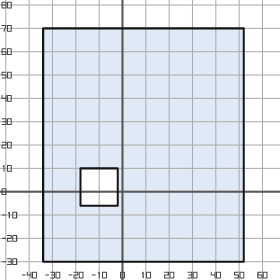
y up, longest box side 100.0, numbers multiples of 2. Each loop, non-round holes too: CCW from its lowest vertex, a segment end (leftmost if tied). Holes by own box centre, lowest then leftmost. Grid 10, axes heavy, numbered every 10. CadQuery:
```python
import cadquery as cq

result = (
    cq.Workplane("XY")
    .moveTo(-34.0, -30.0)
    .lineTo(52.0, -30.0)
    .lineTo(52.0, 70.0)
    .lineTo(-34.0, 70.0)
    .close()
    .moveTo(-18.0, -6.0)
    .lineTo(-2.0, -6.0)
    .lineTo(-2.0, 10.0)
    .lineTo(-18.0, 10.0)
    .close()
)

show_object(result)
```